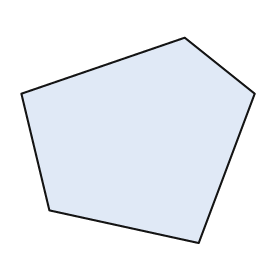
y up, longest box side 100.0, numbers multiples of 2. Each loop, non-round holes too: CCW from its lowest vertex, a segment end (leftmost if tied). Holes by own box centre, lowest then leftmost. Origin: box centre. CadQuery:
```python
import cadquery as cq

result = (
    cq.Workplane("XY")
    .moveTo(26.0, -44.0)
    .lineTo(50.0, 20.0)
    .lineTo(20.0, 44.0)
    .lineTo(-50.0, 20.0)
    .lineTo(-38.0, -30.0)
    .close()
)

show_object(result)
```